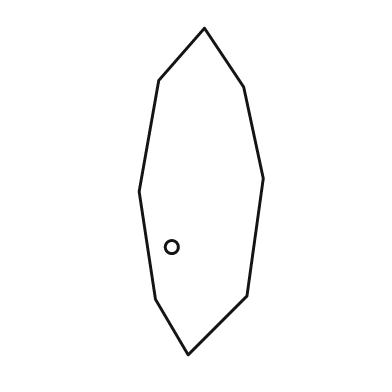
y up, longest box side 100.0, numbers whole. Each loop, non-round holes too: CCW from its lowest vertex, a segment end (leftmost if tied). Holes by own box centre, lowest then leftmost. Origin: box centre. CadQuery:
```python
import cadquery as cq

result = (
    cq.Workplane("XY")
    .moveTo(-4.0, -50.0)
    .lineTo(14.0, -32.0)
    .lineTo(19.0, 4.0)
    .lineTo(13.0, 32.0)
    .lineTo(1.0, 50.0)
    .lineTo(-13.0, 34.0)
    .lineTo(-19.0, 0.0)
    .lineTo(-14.0, -33.0)
    .close()
    .moveTo(-9.0, -17.0)
    .circle(2.0)
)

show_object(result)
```